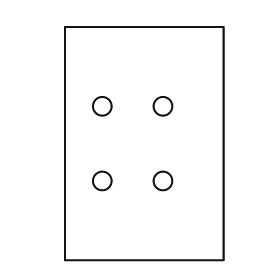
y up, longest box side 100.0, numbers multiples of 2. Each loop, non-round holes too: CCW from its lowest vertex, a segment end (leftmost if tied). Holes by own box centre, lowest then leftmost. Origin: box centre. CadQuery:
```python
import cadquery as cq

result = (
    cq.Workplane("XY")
    .moveTo(-34.0, -50.0)
    .lineTo(34.0, -50.0)
    .lineTo(34.0, 50.0)
    .lineTo(-34.0, 50.0)
    .close()
    .moveTo(-18.0, -16.0)
    .circle(4.0)
    .moveTo(8.0, -16.0)
    .circle(4.0)
    .moveTo(-18.0, 16.0)
    .circle(4.0)
    .moveTo(8.0, 16.0)
    .circle(4.0)
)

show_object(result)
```